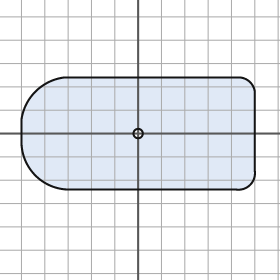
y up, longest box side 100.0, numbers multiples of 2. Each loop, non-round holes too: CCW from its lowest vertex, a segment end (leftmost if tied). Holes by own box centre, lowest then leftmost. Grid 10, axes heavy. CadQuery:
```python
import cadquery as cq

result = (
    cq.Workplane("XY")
    .moveTo(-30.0, -24.0)
    .lineTo(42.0, -24.0)
    .threePointArc((48.0, -22.0), (50.0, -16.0))
    .lineTo(50.0, 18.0)
    .threePointArc((48.0, 22.0), (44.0, 24.0))
    .lineTo(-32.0, 24.0)
    .threePointArc((-44.0, 18.0), (-50.0, 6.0))
    .lineTo(-50.0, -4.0)
    .threePointArc((-44.0, -18.0), (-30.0, -24.0))
    .close()
    .moveTo(0.0, 0.0)
    .circle(2.0)
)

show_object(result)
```